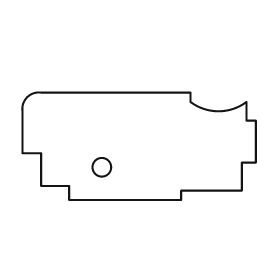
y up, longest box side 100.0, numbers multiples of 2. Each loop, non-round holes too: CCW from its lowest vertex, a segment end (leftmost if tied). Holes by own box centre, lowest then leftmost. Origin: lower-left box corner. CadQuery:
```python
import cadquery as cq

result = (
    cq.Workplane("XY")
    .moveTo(20.0, 0.0)
    .lineTo(68.0, 0.0)
    .lineTo(68.0, 4.0)
    .lineTo(94.0, 4.0)
    .lineTo(94.0, 16.0)
    .lineTo(100.0, 16.0)
    .lineTo(100.0, 34.0)
    .lineTo(96.0, 34.0)
    .lineTo(96.0, 42.0)
    .threePointArc((84.0, 38.0), (72.0, 42.0))
    .lineTo(72.0, 46.0)
    .lineTo(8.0, 46.0)
    .threePointArc((2.0, 44.0), (0.0, 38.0))
    .lineTo(0.0, 20.0)
    .lineTo(8.0, 20.0)
    .lineTo(8.0, 6.0)
    .lineTo(20.0, 6.0)
    .close()
    .moveTo(34.0, 14.0)
    .circle(4.0)
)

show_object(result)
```